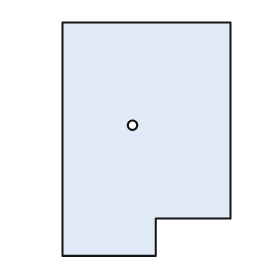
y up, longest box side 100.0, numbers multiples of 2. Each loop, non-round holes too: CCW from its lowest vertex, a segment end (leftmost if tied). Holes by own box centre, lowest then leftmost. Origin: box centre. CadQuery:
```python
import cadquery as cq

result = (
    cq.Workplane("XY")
    .moveTo(-36.0, -50.0)
    .lineTo(4.0, -50.0)
    .lineTo(4.0, -34.0)
    .lineTo(36.0, -34.0)
    .lineTo(36.0, 50.0)
    .lineTo(-36.0, 50.0)
    .close()
    .moveTo(-6.0, 6.0)
    .circle(2.0)
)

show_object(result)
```